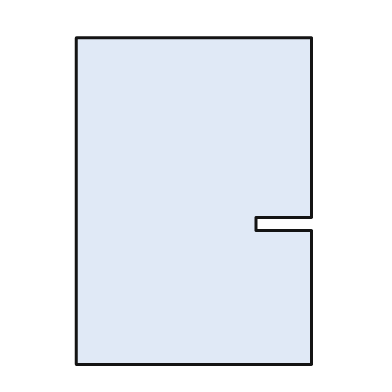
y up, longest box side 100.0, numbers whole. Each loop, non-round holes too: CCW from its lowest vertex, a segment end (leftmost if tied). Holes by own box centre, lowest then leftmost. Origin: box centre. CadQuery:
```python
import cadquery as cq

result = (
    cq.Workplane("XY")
    .moveTo(-36.0, -50.0)
    .lineTo(36.0, -50.0)
    .lineTo(36.0, -9.0)
    .lineTo(19.0, -9.0)
    .lineTo(19.0, -5.0)
    .lineTo(36.0, -5.0)
    .lineTo(36.0, 50.0)
    .lineTo(-36.0, 50.0)
    .close()
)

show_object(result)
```